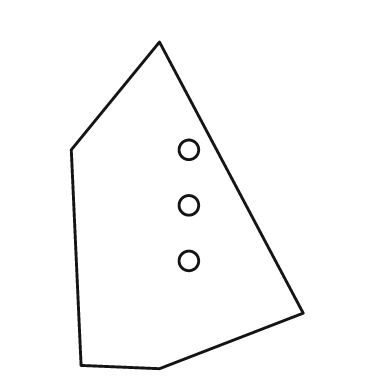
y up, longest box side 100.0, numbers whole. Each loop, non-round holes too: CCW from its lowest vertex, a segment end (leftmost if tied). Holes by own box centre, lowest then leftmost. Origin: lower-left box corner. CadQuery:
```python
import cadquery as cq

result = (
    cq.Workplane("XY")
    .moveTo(27.0, 0.0)
    .lineTo(71.0, 17.0)
    .lineTo(27.0, 100.0)
    .lineTo(0.0, 67.0)
    .lineTo(3.0, 1.0)
    .close()
    .moveTo(36.0, 33.0)
    .circle(3.0)
    .moveTo(36.0, 50.0)
    .circle(3.0)
    .moveTo(36.0, 67.0)
    .circle(3.0)
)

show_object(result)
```